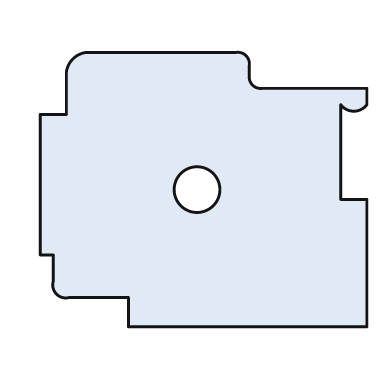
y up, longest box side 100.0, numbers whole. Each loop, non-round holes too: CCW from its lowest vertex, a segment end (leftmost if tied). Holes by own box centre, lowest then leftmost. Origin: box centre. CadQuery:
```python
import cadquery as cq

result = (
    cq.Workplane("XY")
    .moveTo(-23.0, -42.0)
    .lineTo(50.0, -42.0)
    .lineTo(50.0, -3.0)
    .lineTo(42.0, -3.0)
    .lineTo(42.0, 26.0)
    .threePointArc((46.0, 24.0), (50.0, 26.0))
    .lineTo(50.0, 31.0)
    .lineTo(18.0, 31.0)
    .threePointArc((15.0, 32.0), (14.0, 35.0))
    .lineTo(14.0, 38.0)
    .threePointArc((13.0, 41.0), (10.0, 42.0))
    .lineTo(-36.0, 42.0)
    .threePointArc((-40.0, 40.0), (-42.0, 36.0))
    .lineTo(-42.0, 23.0)
    .lineTo(-50.0, 23.0)
    .lineTo(-50.0, -20.0)
    .lineTo(-46.0, -20.0)
    .lineTo(-46.0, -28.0)
    .threePointArc((-45.0, -32.0), (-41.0, -33.0))
    .lineTo(-23.0, -33.0)
    .close()
    .moveTo(-2.0, 0.0)
    .circle(7.0)
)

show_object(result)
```